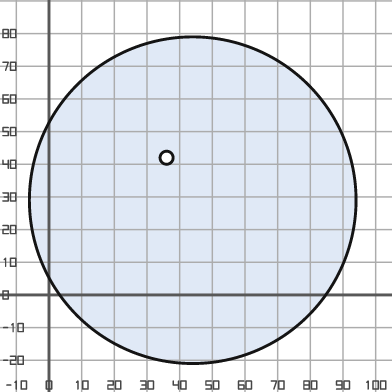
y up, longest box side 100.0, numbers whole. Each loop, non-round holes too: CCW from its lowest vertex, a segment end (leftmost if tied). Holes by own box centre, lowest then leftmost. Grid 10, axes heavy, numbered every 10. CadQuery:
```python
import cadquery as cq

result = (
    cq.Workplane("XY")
    .moveTo(44.0, 29.0)
    .circle(50.0)
    .moveTo(36.0, 42.0)
    .circle(2.0)
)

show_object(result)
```